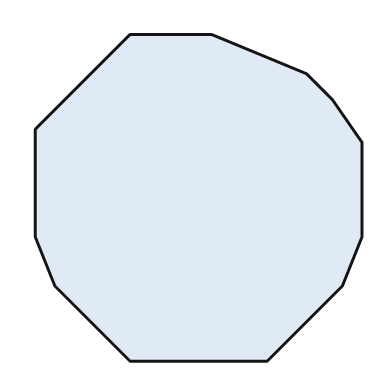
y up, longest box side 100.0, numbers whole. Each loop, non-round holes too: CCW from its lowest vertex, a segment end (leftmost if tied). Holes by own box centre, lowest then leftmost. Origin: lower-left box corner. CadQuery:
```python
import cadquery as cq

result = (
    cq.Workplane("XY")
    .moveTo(29.0, 0.0)
    .lineTo(71.0, 0.0)
    .lineTo(94.0, 23.0)
    .lineTo(100.0, 38.0)
    .lineTo(100.0, 67.0)
    .lineTo(91.0, 80.0)
    .lineTo(83.0, 88.0)
    .lineTo(54.0, 100.0)
    .lineTo(29.0, 100.0)
    .lineTo(0.0, 71.0)
    .lineTo(0.0, 38.0)
    .lineTo(6.0, 23.0)
    .close()
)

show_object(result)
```